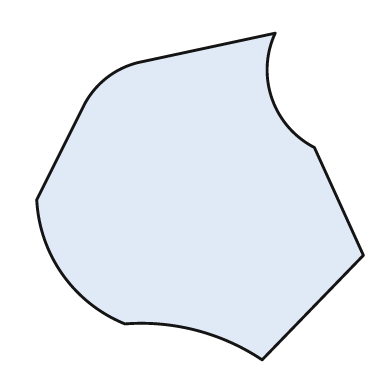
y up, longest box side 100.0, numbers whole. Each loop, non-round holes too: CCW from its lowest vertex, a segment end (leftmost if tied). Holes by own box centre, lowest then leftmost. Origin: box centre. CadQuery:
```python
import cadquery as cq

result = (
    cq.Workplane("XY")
    .moveTo(19.0, -50.0)
    .lineTo(50.0, -18.0)
    .lineTo(35.0, 15.0)
    .threePointArc((22.0, 30.0), (23.0, 50.0))
    .lineTo(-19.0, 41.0)
    .threePointArc((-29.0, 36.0), (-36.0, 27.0))
    .lineTo(-50.0, -1.0)
    .threePointArc((-42.0, -24.0), (-23.0, -39.0))
    .threePointArc((-1.0, -41.0), (19.0, -50.0))
    .close()
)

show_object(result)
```